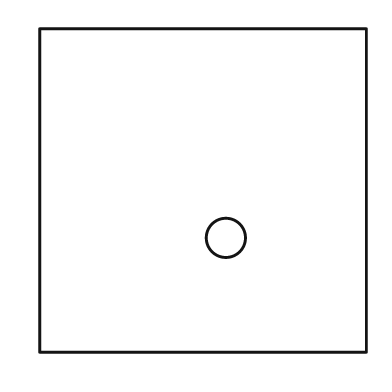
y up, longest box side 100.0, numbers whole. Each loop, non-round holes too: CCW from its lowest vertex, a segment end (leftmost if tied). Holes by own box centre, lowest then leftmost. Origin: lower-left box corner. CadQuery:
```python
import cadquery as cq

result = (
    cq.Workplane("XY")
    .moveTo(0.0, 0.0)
    .lineTo(100.0, 0.0)
    .lineTo(100.0, 99.0)
    .lineTo(0.0, 99.0)
    .close()
    .moveTo(57.0, 35.0)
    .circle(6.0)
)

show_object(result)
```